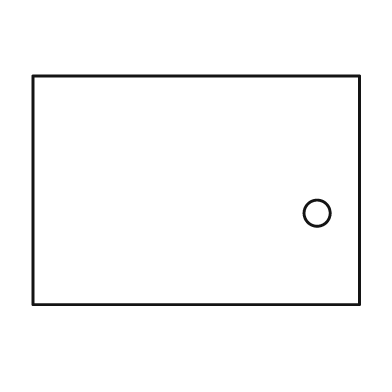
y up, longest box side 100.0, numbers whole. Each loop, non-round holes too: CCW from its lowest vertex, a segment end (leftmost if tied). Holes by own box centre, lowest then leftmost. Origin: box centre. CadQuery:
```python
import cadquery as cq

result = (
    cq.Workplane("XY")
    .moveTo(-50.0, -35.0)
    .lineTo(50.0, -35.0)
    .lineTo(50.0, 35.0)
    .lineTo(-50.0, 35.0)
    .close()
    .moveTo(37.0, -7.0)
    .circle(4.0)
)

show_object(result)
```